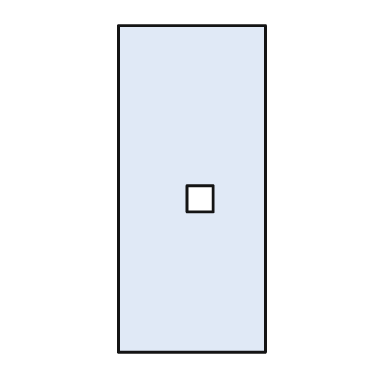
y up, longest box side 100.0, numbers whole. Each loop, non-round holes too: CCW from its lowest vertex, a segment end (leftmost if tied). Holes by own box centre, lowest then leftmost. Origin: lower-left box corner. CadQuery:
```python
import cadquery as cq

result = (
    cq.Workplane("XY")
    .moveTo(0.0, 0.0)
    .lineTo(45.0, 0.0)
    .lineTo(45.0, 100.0)
    .lineTo(0.0, 100.0)
    .close()
    .moveTo(21.0, 43.0)
    .lineTo(29.0, 43.0)
    .lineTo(29.0, 51.0)
    .lineTo(21.0, 51.0)
    .close()
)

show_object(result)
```